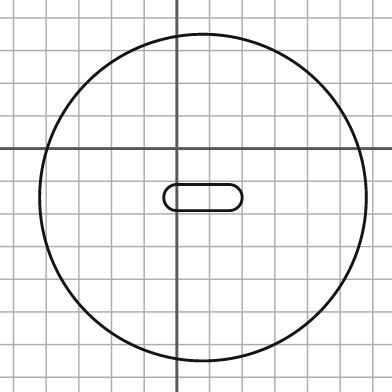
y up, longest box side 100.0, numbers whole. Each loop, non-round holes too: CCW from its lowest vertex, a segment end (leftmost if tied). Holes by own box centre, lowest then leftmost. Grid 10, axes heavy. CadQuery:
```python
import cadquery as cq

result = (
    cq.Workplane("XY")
    .moveTo(8.0, -15.0)
    .circle(50.0)
    .moveTo(0.0, -19.0)
    .lineTo(16.0, -19.0)
    .threePointArc((20.0, -15.0), (16.0, -11.0))
    .lineTo(0.0, -11.0)
    .threePointArc((-4.0, -15.0), (0.0, -19.0))
    .close()
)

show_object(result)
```